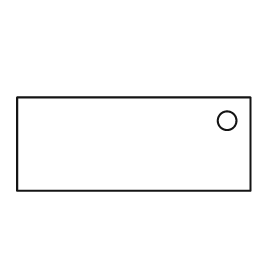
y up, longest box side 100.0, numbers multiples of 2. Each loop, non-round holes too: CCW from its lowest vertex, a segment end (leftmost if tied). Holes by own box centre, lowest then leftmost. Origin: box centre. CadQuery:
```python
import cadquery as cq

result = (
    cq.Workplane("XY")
    .moveTo(-50.0, -20.0)
    .lineTo(50.0, -20.0)
    .lineTo(50.0, 20.0)
    .lineTo(-50.0, 20.0)
    .close()
    .moveTo(40.0, 10.0)
    .circle(4.0)
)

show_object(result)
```